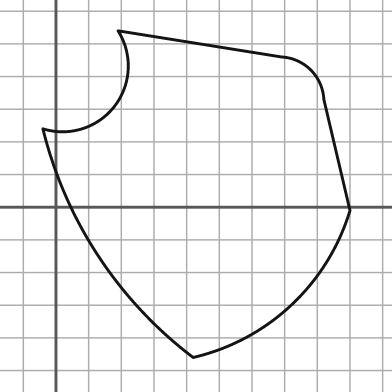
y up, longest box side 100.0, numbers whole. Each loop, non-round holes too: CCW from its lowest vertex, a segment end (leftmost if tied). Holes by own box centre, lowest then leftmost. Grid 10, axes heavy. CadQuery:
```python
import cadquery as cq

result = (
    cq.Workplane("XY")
    .moveTo(42.0, -46.0)
    .threePointArc((72.0, -30.0), (90.0, -1.0))
    .lineTo(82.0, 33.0)
    .threePointArc((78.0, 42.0), (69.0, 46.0))
    .lineTo(19.0, 54.0)
    .threePointArc((18.0, 31.0), (-4.0, 24.0))
    .threePointArc((13.0, -15.0), (42.0, -46.0))
    .close()
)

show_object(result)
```